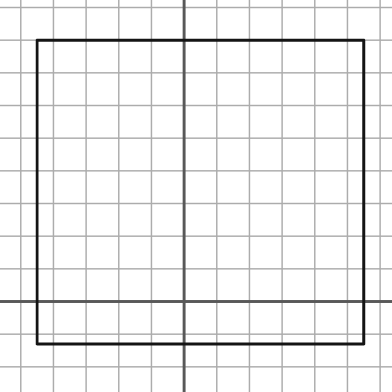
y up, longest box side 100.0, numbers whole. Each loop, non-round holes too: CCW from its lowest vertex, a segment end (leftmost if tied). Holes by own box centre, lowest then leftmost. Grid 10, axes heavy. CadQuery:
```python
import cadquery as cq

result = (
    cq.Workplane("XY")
    .moveTo(-45.0, -13.0)
    .lineTo(55.0, -13.0)
    .lineTo(55.0, 80.0)
    .lineTo(-45.0, 80.0)
    .close()
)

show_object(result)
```